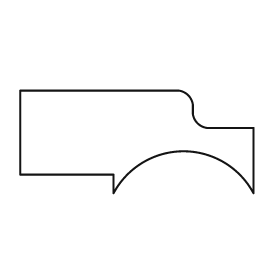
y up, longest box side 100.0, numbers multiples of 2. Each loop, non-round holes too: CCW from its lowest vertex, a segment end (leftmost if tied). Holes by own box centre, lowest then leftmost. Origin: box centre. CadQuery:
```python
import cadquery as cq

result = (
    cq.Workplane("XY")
    .moveTo(-10.0, -22.0)
    .threePointArc((20.0, -4.0), (50.0, -22.0))
    .lineTo(50.0, 6.0)
    .lineTo(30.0, 6.0)
    .threePointArc((26.0, 8.0), (24.0, 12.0))
    .lineTo(24.0, 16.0)
    .threePointArc((22.0, 20.0), (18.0, 22.0))
    .lineTo(-50.0, 22.0)
    .lineTo(-50.0, -14.0)
    .lineTo(-10.0, -14.0)
    .close()
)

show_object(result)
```